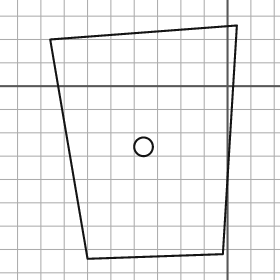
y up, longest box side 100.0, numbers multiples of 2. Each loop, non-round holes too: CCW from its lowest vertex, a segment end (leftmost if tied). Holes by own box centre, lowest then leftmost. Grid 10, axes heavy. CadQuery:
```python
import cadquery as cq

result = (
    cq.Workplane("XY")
    .moveTo(-60.0, -74.0)
    .lineTo(-2.0, -72.0)
    .lineTo(4.0, 26.0)
    .lineTo(-76.0, 20.0)
    .close()
    .moveTo(-36.0, -26.0)
    .circle(4.0)
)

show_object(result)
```